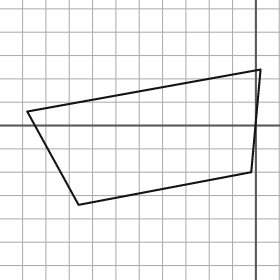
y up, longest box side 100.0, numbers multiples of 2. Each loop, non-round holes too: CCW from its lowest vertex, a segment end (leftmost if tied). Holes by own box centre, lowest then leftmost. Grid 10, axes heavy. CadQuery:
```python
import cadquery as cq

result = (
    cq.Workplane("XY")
    .moveTo(-76.0, -34.0)
    .lineTo(-2.0, -20.0)
    .lineTo(2.0, 24.0)
    .lineTo(-98.0, 6.0)
    .close()
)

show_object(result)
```